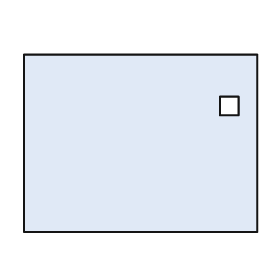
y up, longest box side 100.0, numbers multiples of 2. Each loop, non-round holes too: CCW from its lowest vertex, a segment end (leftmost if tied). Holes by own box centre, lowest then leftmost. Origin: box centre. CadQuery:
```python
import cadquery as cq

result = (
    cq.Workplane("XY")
    .moveTo(-50.0, -38.0)
    .lineTo(50.0, -38.0)
    .lineTo(50.0, 38.0)
    .lineTo(-50.0, 38.0)
    .close()
    .moveTo(34.0, 12.0)
    .lineTo(42.0, 12.0)
    .lineTo(42.0, 20.0)
    .lineTo(34.0, 20.0)
    .close()
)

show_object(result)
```